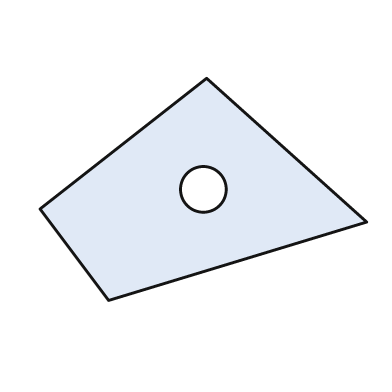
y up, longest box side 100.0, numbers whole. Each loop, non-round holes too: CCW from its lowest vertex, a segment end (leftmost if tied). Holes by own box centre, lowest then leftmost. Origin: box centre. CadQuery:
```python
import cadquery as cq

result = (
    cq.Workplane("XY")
    .moveTo(-29.0, -34.0)
    .lineTo(50.0, -10.0)
    .lineTo(1.0, 34.0)
    .lineTo(-50.0, -6.0)
    .close()
    .moveTo(0.0, 0.0)
    .circle(7.0)
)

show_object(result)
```